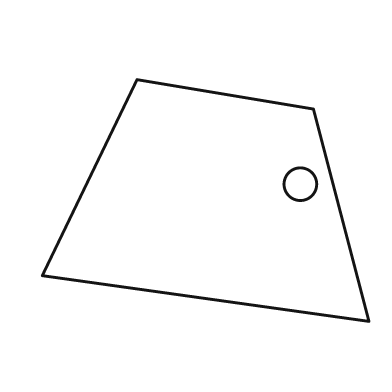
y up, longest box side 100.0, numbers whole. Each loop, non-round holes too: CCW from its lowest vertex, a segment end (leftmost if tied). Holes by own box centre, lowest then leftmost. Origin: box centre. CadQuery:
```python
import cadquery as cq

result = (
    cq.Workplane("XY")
    .moveTo(50.0, -37.0)
    .lineTo(33.0, 28.0)
    .lineTo(-21.0, 37.0)
    .lineTo(-50.0, -23.0)
    .close()
    .moveTo(29.0, 5.0)
    .circle(5.0)
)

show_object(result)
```